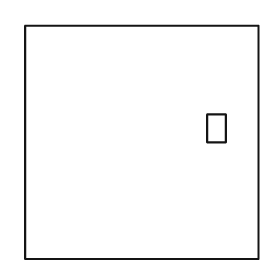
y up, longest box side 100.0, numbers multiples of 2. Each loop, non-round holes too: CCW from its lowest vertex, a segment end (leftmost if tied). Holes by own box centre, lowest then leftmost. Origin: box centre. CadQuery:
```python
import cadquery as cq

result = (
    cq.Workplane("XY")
    .moveTo(-50.0, -50.0)
    .lineTo(50.0, -50.0)
    .lineTo(50.0, 50.0)
    .lineTo(-50.0, 50.0)
    .close()
    .moveTo(28.0, 0.0)
    .lineTo(36.0, 0.0)
    .lineTo(36.0, 12.0)
    .lineTo(28.0, 12.0)
    .close()
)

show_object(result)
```